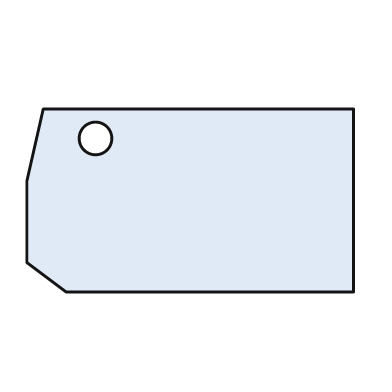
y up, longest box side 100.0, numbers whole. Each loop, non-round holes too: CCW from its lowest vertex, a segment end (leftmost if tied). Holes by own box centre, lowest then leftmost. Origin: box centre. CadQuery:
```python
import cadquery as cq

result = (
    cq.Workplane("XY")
    .moveTo(-38.0, -28.0)
    .lineTo(50.0, -28.0)
    .lineTo(50.0, 28.0)
    .lineTo(-45.0, 28.0)
    .lineTo(-50.0, 6.0)
    .lineTo(-50.0, -19.0)
    .close()
    .moveTo(-29.0, 19.0)
    .circle(5.0)
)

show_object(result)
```